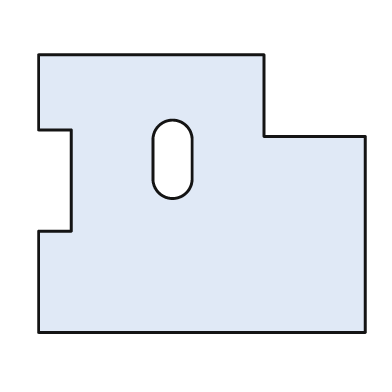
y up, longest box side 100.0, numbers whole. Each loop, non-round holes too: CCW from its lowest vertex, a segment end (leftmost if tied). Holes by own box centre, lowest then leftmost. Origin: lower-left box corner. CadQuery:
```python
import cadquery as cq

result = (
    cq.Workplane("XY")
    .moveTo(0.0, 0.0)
    .lineTo(100.0, 0.0)
    .lineTo(100.0, 60.0)
    .lineTo(69.0, 60.0)
    .lineTo(69.0, 85.0)
    .lineTo(0.0, 85.0)
    .lineTo(0.0, 62.0)
    .lineTo(10.0, 62.0)
    .lineTo(10.0, 31.0)
    .lineTo(0.0, 31.0)
    .close()
    .moveTo(35.0, 47.0)
    .threePointArc((41.0, 41.0), (47.0, 47.0))
    .lineTo(47.0, 59.0)
    .threePointArc((41.0, 65.0), (35.0, 59.0))
    .close()
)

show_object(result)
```